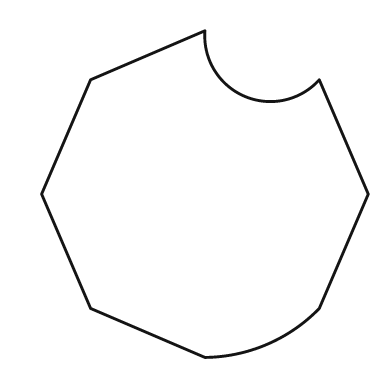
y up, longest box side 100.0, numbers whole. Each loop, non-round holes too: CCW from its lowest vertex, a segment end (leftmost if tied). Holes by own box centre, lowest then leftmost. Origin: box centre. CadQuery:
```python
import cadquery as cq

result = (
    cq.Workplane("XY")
    .moveTo(0.0, -50.0)
    .threePointArc((19.0, -46.0), (35.0, -35.0))
    .lineTo(50.0, 0.0)
    .lineTo(35.0, 35.0)
    .threePointArc((12.0, 30.0), (0.0, 50.0))
    .lineTo(-35.0, 35.0)
    .lineTo(-50.0, 0.0)
    .lineTo(-35.0, -35.0)
    .close()
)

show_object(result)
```